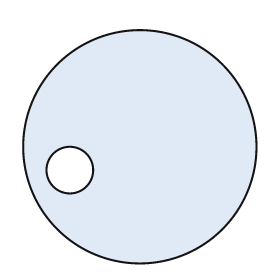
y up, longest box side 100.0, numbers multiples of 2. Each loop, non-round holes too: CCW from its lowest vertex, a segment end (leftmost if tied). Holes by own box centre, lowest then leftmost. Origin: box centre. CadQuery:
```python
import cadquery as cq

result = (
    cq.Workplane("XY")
    .moveTo(0.0, 0.0)
    .circle(50.0)
    .moveTo(-30.0, -10.0)
    .circle(10.0)
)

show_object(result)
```